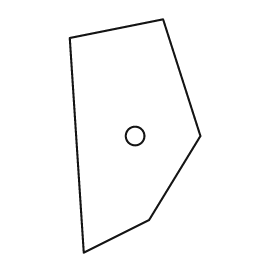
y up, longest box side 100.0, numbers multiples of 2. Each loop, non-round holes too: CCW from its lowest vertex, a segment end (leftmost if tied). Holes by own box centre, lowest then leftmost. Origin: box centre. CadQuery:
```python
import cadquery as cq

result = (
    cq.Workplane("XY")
    .moveTo(-22.0, -50.0)
    .lineTo(6.0, -36.0)
    .lineTo(28.0, 0.0)
    .lineTo(12.0, 50.0)
    .lineTo(-28.0, 42.0)
    .close()
    .moveTo(0.0, 0.0)
    .circle(4.0)
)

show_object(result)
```